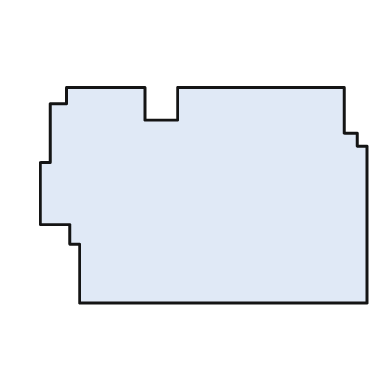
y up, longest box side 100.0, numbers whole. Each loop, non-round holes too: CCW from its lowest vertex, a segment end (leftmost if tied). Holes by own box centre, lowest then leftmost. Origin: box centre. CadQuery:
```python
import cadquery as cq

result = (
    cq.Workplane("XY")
    .moveTo(-38.0, -33.0)
    .lineTo(50.0, -33.0)
    .lineTo(50.0, 15.0)
    .lineTo(47.0, 15.0)
    .lineTo(47.0, 19.0)
    .lineTo(43.0, 19.0)
    .lineTo(43.0, 33.0)
    .lineTo(-8.0, 33.0)
    .lineTo(-8.0, 23.0)
    .lineTo(-18.0, 23.0)
    .lineTo(-18.0, 33.0)
    .lineTo(-42.0, 33.0)
    .lineTo(-42.0, 28.0)
    .lineTo(-47.0, 28.0)
    .lineTo(-47.0, 10.0)
    .lineTo(-50.0, 10.0)
    .lineTo(-50.0, -9.0)
    .lineTo(-41.0, -9.0)
    .lineTo(-41.0, -15.0)
    .lineTo(-38.0, -15.0)
    .close()
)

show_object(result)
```